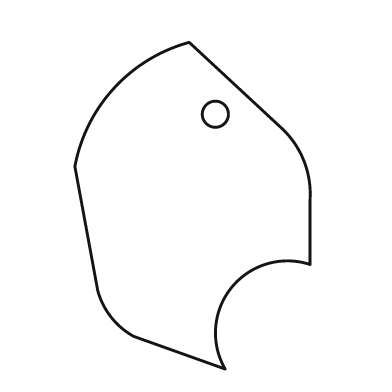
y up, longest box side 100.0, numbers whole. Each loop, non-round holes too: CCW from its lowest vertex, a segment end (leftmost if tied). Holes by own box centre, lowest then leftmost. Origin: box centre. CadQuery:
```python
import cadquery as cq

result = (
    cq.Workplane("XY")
    .moveTo(10.0, -50.0)
    .threePointArc((12.0, -25.0), (36.0, -18.0))
    .lineTo(36.0, 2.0)
    .threePointArc((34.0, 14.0), (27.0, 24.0))
    .lineTo(-1.0, 50.0)
    .threePointArc((-24.0, 36.0), (-36.0, 12.0))
    .lineTo(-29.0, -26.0)
    .threePointArc((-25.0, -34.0), (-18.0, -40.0))
    .close()
    .moveTo(7.0, 28.0)
    .circle(4.0)
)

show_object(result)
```